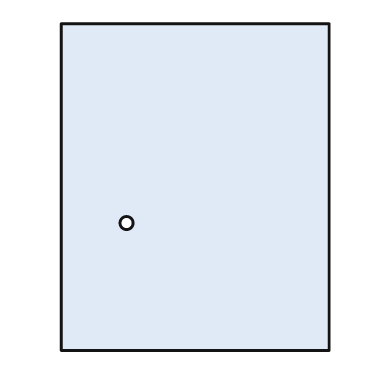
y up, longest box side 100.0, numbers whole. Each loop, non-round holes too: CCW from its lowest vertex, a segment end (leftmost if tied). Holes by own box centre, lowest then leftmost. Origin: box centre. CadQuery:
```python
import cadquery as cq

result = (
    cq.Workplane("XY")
    .moveTo(-41.0, -50.0)
    .lineTo(41.0, -50.0)
    .lineTo(41.0, 50.0)
    .lineTo(-41.0, 50.0)
    .close()
    .moveTo(-21.0, -11.0)
    .circle(2.0)
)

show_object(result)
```